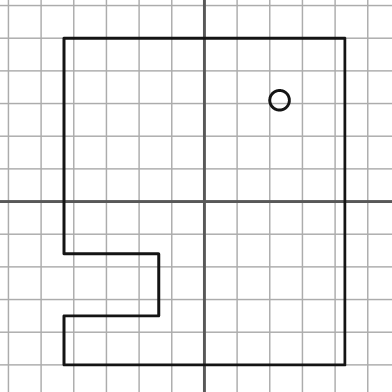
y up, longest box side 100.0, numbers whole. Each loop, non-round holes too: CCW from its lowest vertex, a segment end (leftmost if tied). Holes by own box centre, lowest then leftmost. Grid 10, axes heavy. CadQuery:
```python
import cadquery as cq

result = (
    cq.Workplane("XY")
    .moveTo(-43.0, -50.0)
    .lineTo(43.0, -50.0)
    .lineTo(43.0, 50.0)
    .lineTo(-43.0, 50.0)
    .lineTo(-43.0, -16.0)
    .lineTo(-14.0, -16.0)
    .lineTo(-14.0, -35.0)
    .lineTo(-43.0, -35.0)
    .close()
    .moveTo(23.0, 31.0)
    .circle(3.0)
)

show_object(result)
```